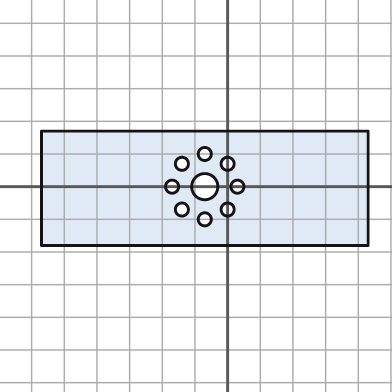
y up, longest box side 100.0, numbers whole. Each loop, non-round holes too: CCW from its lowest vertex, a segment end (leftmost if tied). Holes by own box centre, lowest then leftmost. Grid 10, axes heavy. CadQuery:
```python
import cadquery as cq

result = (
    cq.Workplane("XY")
    .moveTo(-57.0, -18.0)
    .lineTo(43.0, -18.0)
    .lineTo(43.0, 17.0)
    .lineTo(-57.0, 17.0)
    .close()
    .moveTo(-7.0, -10.0)
    .circle(2.0)
    .moveTo(-14.0, -7.0)
    .circle(2.0)
    .moveTo(0.0, -7.0)
    .circle(2.0)
    .moveTo(-17.0, 0.0)
    .circle(2.0)
    .moveTo(-7.0, 0.0)
    .circle(4.0)
    .moveTo(3.0, 0.0)
    .circle(2.0)
    .moveTo(-14.0, 7.0)
    .circle(2.0)
    .moveTo(0.0, 7.0)
    .circle(2.0)
    .moveTo(-7.0, 10.0)
    .circle(2.0)
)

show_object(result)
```